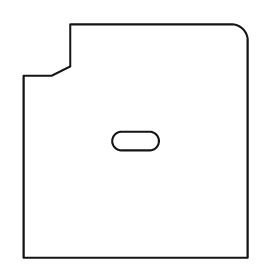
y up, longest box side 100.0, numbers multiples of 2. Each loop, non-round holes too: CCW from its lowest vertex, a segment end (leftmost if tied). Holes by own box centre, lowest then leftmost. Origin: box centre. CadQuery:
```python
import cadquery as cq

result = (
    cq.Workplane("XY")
    .moveTo(-48.0, -50.0)
    .lineTo(48.0, -50.0)
    .lineTo(48.0, 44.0)
    .threePointArc((46.0, 48.0), (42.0, 50.0))
    .lineTo(-28.0, 50.0)
    .lineTo(-28.0, 32.0)
    .lineTo(-36.0, 28.0)
    .lineTo(-48.0, 28.0)
    .close()
    .moveTo(-6.0, -4.0)
    .lineTo(6.0, -4.0)
    .threePointArc((10.0, 0.0), (6.0, 4.0))
    .lineTo(-6.0, 4.0)
    .threePointArc((-10.0, 0.0), (-6.0, -4.0))
    .close()
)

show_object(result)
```